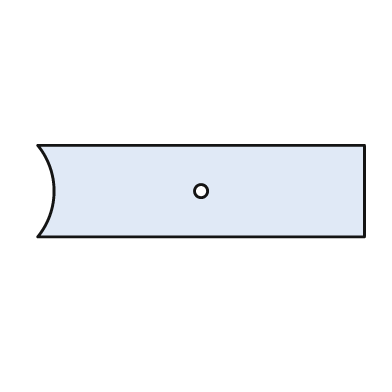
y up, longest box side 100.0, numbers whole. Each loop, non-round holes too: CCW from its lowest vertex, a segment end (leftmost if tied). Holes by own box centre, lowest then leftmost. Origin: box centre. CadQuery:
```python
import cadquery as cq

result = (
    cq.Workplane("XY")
    .moveTo(-50.0, -14.0)
    .lineTo(50.0, -14.0)
    .lineTo(50.0, 14.0)
    .lineTo(-50.0, 14.0)
    .threePointArc((-45.0, 0.0), (-50.0, -14.0))
    .close()
    .moveTo(0.0, 0.0)
    .circle(2.0)
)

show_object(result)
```